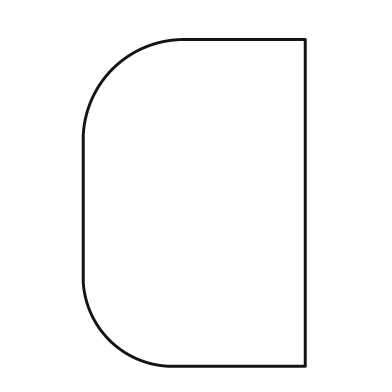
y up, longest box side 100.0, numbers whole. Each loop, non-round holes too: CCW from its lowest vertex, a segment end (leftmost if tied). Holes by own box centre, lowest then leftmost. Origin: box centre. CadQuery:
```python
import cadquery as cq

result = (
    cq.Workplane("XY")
    .moveTo(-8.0, -50.0)
    .lineTo(34.0, -50.0)
    .lineTo(34.0, 50.0)
    .lineTo(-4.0, 50.0)
    .threePointArc((-25.0, 41.0), (-34.0, 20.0))
    .lineTo(-34.0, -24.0)
    .threePointArc((-26.0, -42.0), (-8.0, -50.0))
    .close()
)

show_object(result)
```